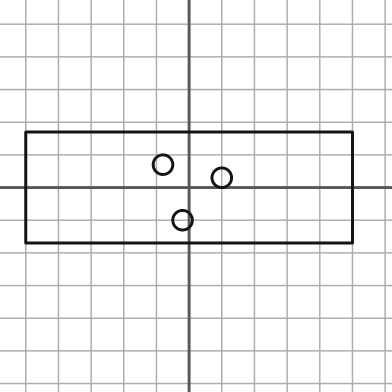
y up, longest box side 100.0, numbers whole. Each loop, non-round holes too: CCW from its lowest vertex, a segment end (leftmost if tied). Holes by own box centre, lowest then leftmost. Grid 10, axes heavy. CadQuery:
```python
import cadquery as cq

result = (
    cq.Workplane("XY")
    .moveTo(-50.0, -17.0)
    .lineTo(50.0, -17.0)
    .lineTo(50.0, 17.0)
    .lineTo(-50.0, 17.0)
    .close()
    .moveTo(-2.0, -10.0)
    .circle(3.0)
    .moveTo(10.0, 3.0)
    .circle(3.0)
    .moveTo(-8.0, 7.0)
    .circle(3.0)
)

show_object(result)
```